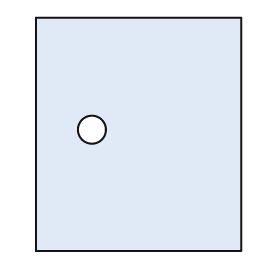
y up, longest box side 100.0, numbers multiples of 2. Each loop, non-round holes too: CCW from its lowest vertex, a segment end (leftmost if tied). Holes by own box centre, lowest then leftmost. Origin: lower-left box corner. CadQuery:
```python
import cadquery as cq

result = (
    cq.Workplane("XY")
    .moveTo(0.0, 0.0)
    .lineTo(88.0, 0.0)
    .lineTo(88.0, 100.0)
    .lineTo(0.0, 100.0)
    .close()
    .moveTo(24.0, 52.0)
    .circle(6.0)
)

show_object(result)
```